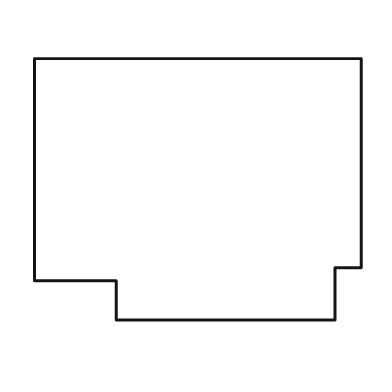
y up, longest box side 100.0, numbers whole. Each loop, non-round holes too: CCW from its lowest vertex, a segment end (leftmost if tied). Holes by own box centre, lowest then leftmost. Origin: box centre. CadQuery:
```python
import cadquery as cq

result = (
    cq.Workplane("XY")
    .moveTo(-25.0, -40.0)
    .lineTo(42.0, -40.0)
    .lineTo(42.0, -24.0)
    .lineTo(50.0, -24.0)
    .lineTo(50.0, 40.0)
    .lineTo(-50.0, 40.0)
    .lineTo(-50.0, -28.0)
    .lineTo(-25.0, -28.0)
    .close()
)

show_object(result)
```